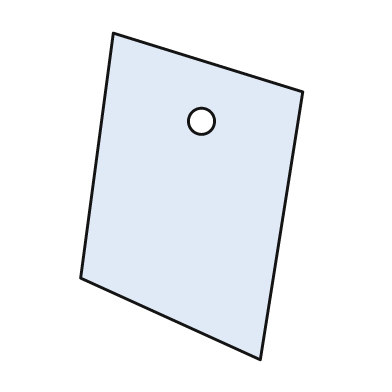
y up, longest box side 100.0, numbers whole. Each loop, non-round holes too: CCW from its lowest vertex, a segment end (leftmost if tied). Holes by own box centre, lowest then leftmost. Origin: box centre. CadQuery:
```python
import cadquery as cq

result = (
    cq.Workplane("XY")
    .moveTo(21.0, -50.0)
    .lineTo(34.0, 32.0)
    .lineTo(-24.0, 50.0)
    .lineTo(-34.0, -25.0)
    .close()
    .moveTo(3.0, 23.0)
    .circle(4.0)
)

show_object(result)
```